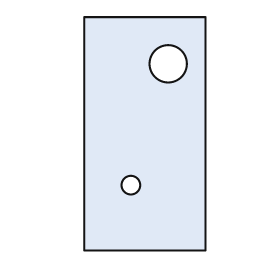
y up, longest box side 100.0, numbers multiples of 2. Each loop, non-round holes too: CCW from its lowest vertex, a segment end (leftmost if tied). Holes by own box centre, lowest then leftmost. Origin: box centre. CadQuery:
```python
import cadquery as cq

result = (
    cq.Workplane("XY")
    .moveTo(-26.0, -50.0)
    .lineTo(26.0, -50.0)
    .lineTo(26.0, 50.0)
    .lineTo(-26.0, 50.0)
    .close()
    .moveTo(-6.0, -22.0)
    .circle(4.0)
    .moveTo(10.0, 30.0)
    .circle(8.0)
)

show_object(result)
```